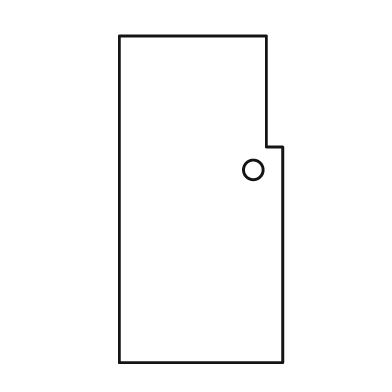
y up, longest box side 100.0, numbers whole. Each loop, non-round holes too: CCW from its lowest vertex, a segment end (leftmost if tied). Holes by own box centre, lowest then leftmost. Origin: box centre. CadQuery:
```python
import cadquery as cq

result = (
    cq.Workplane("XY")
    .moveTo(-25.0, -50.0)
    .lineTo(25.0, -50.0)
    .lineTo(25.0, 16.0)
    .lineTo(20.0, 16.0)
    .lineTo(20.0, 50.0)
    .lineTo(-25.0, 50.0)
    .close()
    .moveTo(16.0, 9.0)
    .circle(3.0)
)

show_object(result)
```